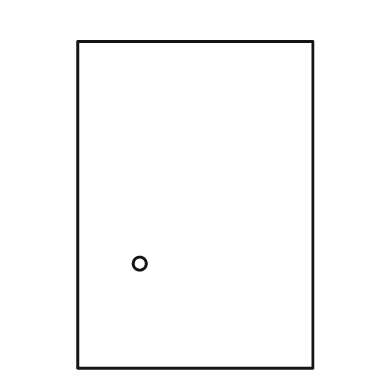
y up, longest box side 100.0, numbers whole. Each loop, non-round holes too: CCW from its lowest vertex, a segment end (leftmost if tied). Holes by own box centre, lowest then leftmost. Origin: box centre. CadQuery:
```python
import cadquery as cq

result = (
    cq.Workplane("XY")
    .moveTo(-36.0, -50.0)
    .lineTo(36.0, -50.0)
    .lineTo(36.0, 50.0)
    .lineTo(-36.0, 50.0)
    .close()
    .moveTo(-17.0, -18.0)
    .circle(2.0)
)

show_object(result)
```